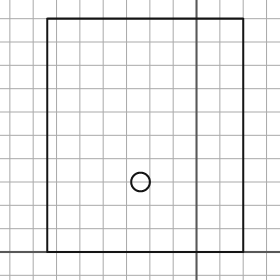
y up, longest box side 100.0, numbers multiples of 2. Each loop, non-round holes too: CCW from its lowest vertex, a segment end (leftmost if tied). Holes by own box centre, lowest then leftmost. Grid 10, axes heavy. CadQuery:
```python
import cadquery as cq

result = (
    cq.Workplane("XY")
    .moveTo(-64.0, 0.0)
    .lineTo(20.0, 0.0)
    .lineTo(20.0, 100.0)
    .lineTo(-64.0, 100.0)
    .close()
    .moveTo(-24.0, 30.0)
    .circle(4.0)
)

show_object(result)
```